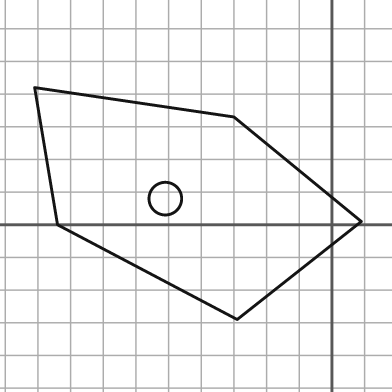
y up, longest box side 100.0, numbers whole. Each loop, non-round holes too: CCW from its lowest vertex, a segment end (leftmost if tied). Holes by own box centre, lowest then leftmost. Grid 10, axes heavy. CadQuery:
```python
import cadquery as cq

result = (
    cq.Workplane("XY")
    .moveTo(-29.0, -29.0)
    .lineTo(9.0, 1.0)
    .lineTo(-30.0, 33.0)
    .lineTo(-91.0, 42.0)
    .lineTo(-84.0, 0.0)
    .close()
    .moveTo(-51.0, 8.0)
    .circle(5.0)
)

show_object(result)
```